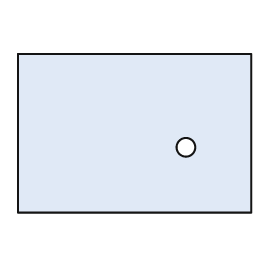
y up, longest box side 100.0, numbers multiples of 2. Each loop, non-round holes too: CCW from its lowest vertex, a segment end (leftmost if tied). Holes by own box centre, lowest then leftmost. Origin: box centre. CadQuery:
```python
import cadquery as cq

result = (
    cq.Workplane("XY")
    .moveTo(-50.0, -34.0)
    .lineTo(50.0, -34.0)
    .lineTo(50.0, 34.0)
    .lineTo(-50.0, 34.0)
    .close()
    .moveTo(22.0, -6.0)
    .circle(4.0)
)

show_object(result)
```